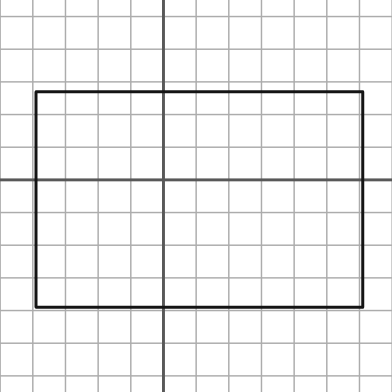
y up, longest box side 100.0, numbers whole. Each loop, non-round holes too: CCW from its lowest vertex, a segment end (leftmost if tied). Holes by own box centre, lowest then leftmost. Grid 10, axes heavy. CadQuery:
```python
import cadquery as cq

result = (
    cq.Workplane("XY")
    .moveTo(-39.0, -39.0)
    .lineTo(61.0, -39.0)
    .lineTo(61.0, 27.0)
    .lineTo(-39.0, 27.0)
    .close()
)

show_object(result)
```